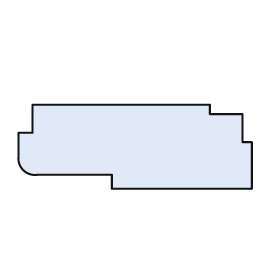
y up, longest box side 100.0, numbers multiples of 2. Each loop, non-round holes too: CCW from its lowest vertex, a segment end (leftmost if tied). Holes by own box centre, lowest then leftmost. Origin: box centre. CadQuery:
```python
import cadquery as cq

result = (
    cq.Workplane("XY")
    .moveTo(-10.0, -18.0)
    .lineTo(50.0, -18.0)
    .lineTo(50.0, 2.0)
    .lineTo(46.0, 2.0)
    .lineTo(46.0, 14.0)
    .lineTo(32.0, 14.0)
    .lineTo(32.0, 18.0)
    .lineTo(-44.0, 18.0)
    .lineTo(-44.0, 6.0)
    .lineTo(-50.0, 6.0)
    .lineTo(-50.0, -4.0)
    .threePointArc((-48.0, -10.0), (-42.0, -12.0))
    .lineTo(-10.0, -12.0)
    .close()
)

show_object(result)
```